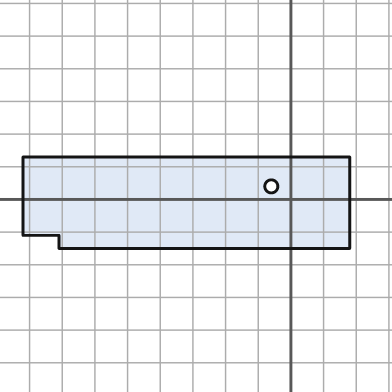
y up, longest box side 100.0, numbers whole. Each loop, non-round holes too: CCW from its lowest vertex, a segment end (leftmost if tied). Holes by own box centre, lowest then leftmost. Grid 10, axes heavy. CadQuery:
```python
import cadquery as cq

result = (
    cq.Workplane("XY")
    .moveTo(-71.0, -15.0)
    .lineTo(18.0, -15.0)
    .lineTo(18.0, 13.0)
    .lineTo(-82.0, 13.0)
    .lineTo(-82.0, -11.0)
    .lineTo(-71.0, -11.0)
    .close()
    .moveTo(-6.0, 4.0)
    .circle(2.0)
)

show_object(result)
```